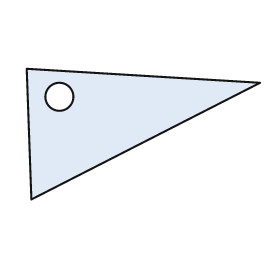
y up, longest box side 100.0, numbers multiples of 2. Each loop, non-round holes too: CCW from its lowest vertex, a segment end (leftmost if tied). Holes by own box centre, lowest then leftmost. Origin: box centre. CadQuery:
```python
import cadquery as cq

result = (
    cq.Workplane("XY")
    .moveTo(-48.0, -28.0)
    .lineTo(50.0, 22.0)
    .lineTo(-50.0, 28.0)
    .close()
    .moveTo(-36.0, 16.0)
    .circle(6.0)
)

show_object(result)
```